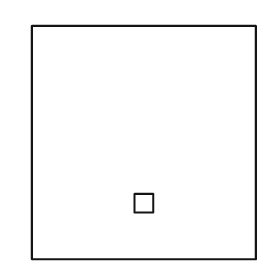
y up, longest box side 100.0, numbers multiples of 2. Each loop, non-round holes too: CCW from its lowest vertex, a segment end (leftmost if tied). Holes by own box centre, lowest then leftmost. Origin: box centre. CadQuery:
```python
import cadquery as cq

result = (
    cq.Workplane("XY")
    .moveTo(-48.0, -50.0)
    .lineTo(48.0, -50.0)
    .lineTo(48.0, 50.0)
    .lineTo(-48.0, 50.0)
    .close()
    .moveTo(-4.0, -30.0)
    .lineTo(4.0, -30.0)
    .lineTo(4.0, -22.0)
    .lineTo(-4.0, -22.0)
    .close()
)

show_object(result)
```